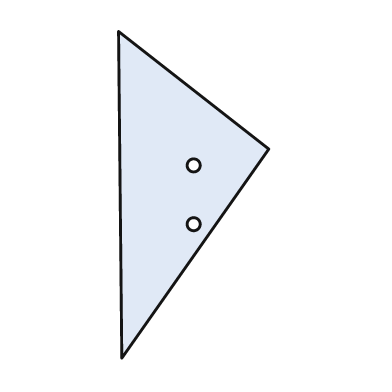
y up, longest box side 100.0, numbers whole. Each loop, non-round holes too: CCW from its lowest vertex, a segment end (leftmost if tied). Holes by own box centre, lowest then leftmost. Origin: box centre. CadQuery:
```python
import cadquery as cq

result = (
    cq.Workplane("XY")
    .moveTo(-22.0, -50.0)
    .lineTo(23.0, 14.0)
    .lineTo(-23.0, 50.0)
    .close()
    .moveTo(0.0, -9.0)
    .circle(2.0)
    .moveTo(0.0, 9.0)
    .circle(2.0)
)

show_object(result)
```